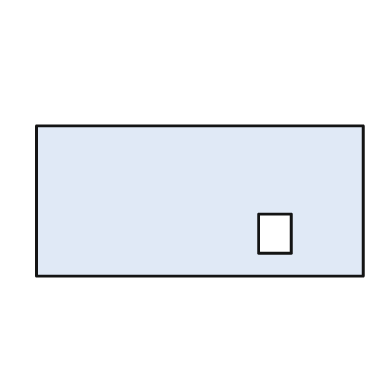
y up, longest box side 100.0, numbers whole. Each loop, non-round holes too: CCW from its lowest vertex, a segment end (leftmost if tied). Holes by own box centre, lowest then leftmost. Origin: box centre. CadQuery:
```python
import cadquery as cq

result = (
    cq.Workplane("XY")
    .moveTo(-50.0, -23.0)
    .lineTo(50.0, -23.0)
    .lineTo(50.0, 23.0)
    .lineTo(-50.0, 23.0)
    .close()
    .moveTo(18.0, -16.0)
    .lineTo(28.0, -16.0)
    .lineTo(28.0, -4.0)
    .lineTo(18.0, -4.0)
    .close()
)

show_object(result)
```